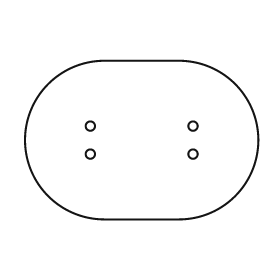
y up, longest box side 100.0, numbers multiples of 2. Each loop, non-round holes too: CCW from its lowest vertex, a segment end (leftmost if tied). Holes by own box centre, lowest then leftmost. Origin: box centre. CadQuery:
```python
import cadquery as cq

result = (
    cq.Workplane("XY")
    .moveTo(-16.0, -34.0)
    .lineTo(16.0, -34.0)
    .threePointArc((50.0, 0.0), (16.0, 34.0))
    .lineTo(-16.0, 34.0)
    .threePointArc((-50.0, 0.0), (-16.0, -34.0))
    .close()
    .moveTo(-22.0, -6.0)
    .circle(2.0)
    .moveTo(22.0, -6.0)
    .circle(2.0)
    .moveTo(-22.0, 6.0)
    .circle(2.0)
    .moveTo(22.0, 6.0)
    .circle(2.0)
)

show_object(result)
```